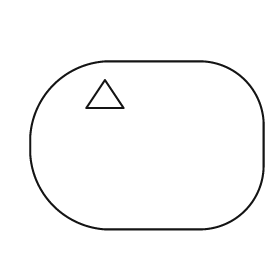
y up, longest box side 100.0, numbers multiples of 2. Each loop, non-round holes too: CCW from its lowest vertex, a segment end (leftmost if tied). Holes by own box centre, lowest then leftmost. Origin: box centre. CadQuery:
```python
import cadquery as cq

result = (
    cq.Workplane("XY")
    .moveTo(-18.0, -36.0)
    .lineTo(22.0, -36.0)
    .threePointArc((42.0, -28.0), (50.0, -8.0))
    .lineTo(50.0, 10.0)
    .threePointArc((42.0, 28.0), (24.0, 36.0))
    .lineTo(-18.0, 36.0)
    .threePointArc((-40.0, 26.0), (-50.0, 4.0))
    .lineTo(-50.0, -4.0)
    .threePointArc((-40.0, -26.0), (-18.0, -36.0))
    .close()
    .moveTo(-26.0, 16.0)
    .lineTo(-10.0, 16.0)
    .lineTo(-18.0, 28.0)
    .close()
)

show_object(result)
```